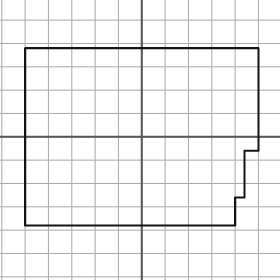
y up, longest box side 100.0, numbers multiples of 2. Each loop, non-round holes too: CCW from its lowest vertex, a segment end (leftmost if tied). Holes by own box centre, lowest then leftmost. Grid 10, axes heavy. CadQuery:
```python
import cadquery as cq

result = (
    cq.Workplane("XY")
    .moveTo(-50.0, -38.0)
    .lineTo(40.0, -38.0)
    .lineTo(40.0, -26.0)
    .lineTo(44.0, -26.0)
    .lineTo(44.0, -6.0)
    .lineTo(50.0, -6.0)
    .lineTo(50.0, 38.0)
    .lineTo(-50.0, 38.0)
    .close()
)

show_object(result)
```